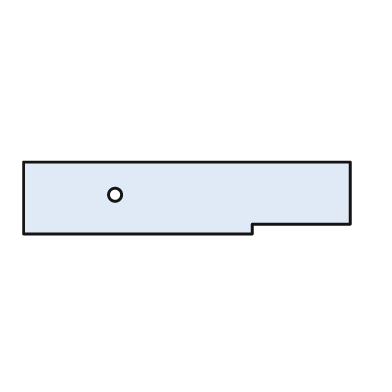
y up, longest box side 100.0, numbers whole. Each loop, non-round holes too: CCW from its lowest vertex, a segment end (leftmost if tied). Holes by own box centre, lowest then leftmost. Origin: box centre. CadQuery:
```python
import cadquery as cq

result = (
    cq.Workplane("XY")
    .moveTo(-50.0, -11.0)
    .lineTo(20.0, -11.0)
    .lineTo(20.0, -8.0)
    .lineTo(50.0, -8.0)
    .lineTo(50.0, 11.0)
    .lineTo(-50.0, 11.0)
    .close()
    .moveTo(-22.0, 1.0)
    .circle(2.0)
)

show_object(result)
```